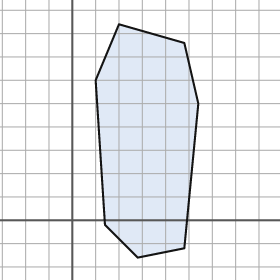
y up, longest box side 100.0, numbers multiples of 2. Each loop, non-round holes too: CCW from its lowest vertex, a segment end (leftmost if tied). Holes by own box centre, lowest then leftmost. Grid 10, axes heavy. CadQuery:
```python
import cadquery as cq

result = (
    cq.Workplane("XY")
    .moveTo(28.0, -16.0)
    .lineTo(48.0, -12.0)
    .lineTo(54.0, 50.0)
    .lineTo(48.0, 76.0)
    .lineTo(20.0, 84.0)
    .lineTo(10.0, 60.0)
    .lineTo(14.0, -2.0)
    .close()
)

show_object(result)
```